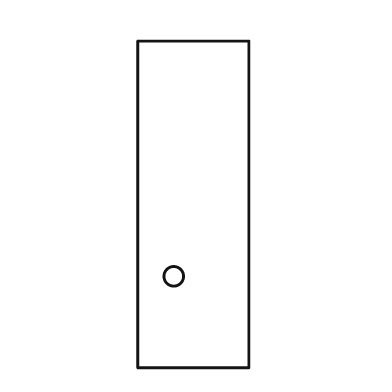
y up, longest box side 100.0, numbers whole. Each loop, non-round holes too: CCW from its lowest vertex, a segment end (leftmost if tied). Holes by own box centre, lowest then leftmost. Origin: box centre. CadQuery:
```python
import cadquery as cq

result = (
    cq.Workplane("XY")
    .moveTo(-17.0, -50.0)
    .lineTo(17.0, -50.0)
    .lineTo(17.0, 50.0)
    .lineTo(-17.0, 50.0)
    .close()
    .moveTo(-6.0, -22.0)
    .circle(3.0)
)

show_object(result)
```